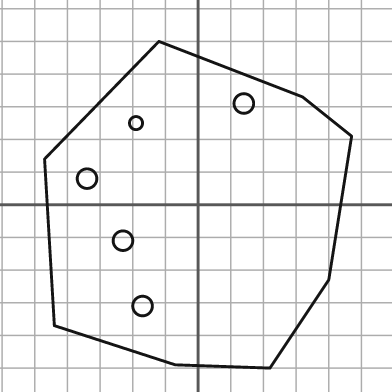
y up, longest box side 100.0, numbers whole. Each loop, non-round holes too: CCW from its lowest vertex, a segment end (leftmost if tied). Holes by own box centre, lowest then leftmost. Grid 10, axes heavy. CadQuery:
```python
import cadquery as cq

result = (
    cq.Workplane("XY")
    .moveTo(22.0, -50.0)
    .lineTo(40.0, -23.0)
    .lineTo(47.0, 21.0)
    .lineTo(32.0, 33.0)
    .lineTo(-12.0, 50.0)
    .lineTo(-47.0, 14.0)
    .lineTo(-44.0, -37.0)
    .lineTo(-7.0, -49.0)
    .close()
    .moveTo(-17.0, -31.0)
    .circle(3.0)
    .moveTo(-23.0, -11.0)
    .circle(3.0)
    .moveTo(-34.0, 8.0)
    .circle(3.0)
    .moveTo(-19.0, 25.0)
    .circle(2.0)
    .moveTo(14.0, 31.0)
    .circle(3.0)
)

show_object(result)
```